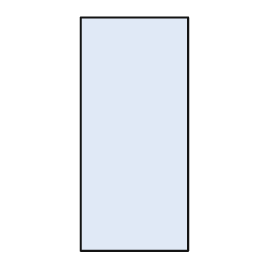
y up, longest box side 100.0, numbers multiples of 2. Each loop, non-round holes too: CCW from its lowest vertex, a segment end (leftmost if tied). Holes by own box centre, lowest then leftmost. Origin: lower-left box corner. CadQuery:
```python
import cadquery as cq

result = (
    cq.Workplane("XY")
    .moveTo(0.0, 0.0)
    .lineTo(46.0, 0.0)
    .lineTo(46.0, 100.0)
    .lineTo(0.0, 100.0)
    .close()
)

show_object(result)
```